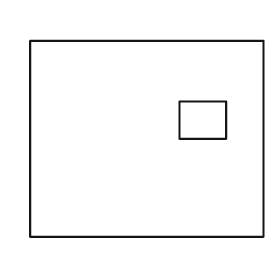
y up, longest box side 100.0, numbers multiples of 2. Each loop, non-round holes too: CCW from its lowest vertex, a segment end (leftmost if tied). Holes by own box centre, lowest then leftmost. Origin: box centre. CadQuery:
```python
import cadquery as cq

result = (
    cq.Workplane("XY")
    .moveTo(-50.0, -42.0)
    .lineTo(50.0, -42.0)
    .lineTo(50.0, 42.0)
    .lineTo(-50.0, 42.0)
    .close()
    .moveTo(14.0, 0.0)
    .lineTo(34.0, 0.0)
    .lineTo(34.0, 16.0)
    .lineTo(14.0, 16.0)
    .close()
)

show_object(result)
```